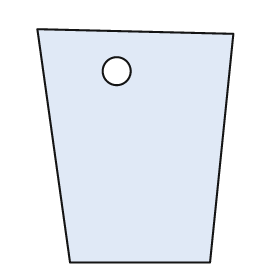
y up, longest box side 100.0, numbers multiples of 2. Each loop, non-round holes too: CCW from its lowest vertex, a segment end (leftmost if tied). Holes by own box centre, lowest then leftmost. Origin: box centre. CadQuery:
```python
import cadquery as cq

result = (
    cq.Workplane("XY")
    .moveTo(-28.0, -50.0)
    .lineTo(32.0, -50.0)
    .lineTo(42.0, 48.0)
    .lineTo(-42.0, 50.0)
    .close()
    .moveTo(-8.0, 32.0)
    .circle(6.0)
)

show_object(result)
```